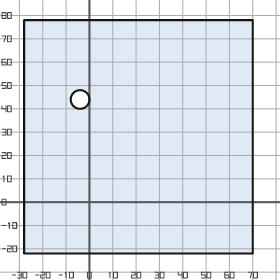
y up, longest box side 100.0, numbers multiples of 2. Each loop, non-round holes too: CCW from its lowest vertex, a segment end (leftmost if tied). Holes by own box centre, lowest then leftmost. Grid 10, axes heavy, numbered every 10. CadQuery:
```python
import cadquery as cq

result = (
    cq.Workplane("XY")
    .moveTo(-28.0, -22.0)
    .lineTo(70.0, -22.0)
    .lineTo(70.0, 78.0)
    .lineTo(-28.0, 78.0)
    .close()
    .moveTo(-4.0, 44.0)
    .circle(4.0)
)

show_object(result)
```